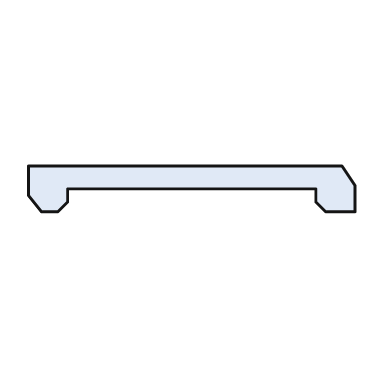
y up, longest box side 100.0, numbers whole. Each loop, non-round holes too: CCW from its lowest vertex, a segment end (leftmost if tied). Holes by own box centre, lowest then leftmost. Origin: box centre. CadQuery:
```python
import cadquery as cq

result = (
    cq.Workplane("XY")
    .moveTo(-46.0, -7.0)
    .lineTo(-41.0, -7.0)
    .lineTo(-38.0, -4.0)
    .lineTo(-38.0, 0.0)
    .lineTo(38.0, 0.0)
    .lineTo(38.0, -4.0)
    .lineTo(41.0, -7.0)
    .lineTo(50.0, -7.0)
    .lineTo(50.0, 1.0)
    .lineTo(46.0, 7.0)
    .lineTo(-50.0, 7.0)
    .lineTo(-50.0, -2.0)
    .close()
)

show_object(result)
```